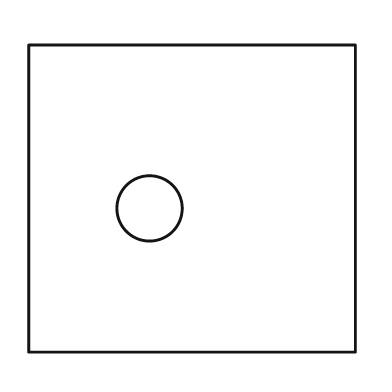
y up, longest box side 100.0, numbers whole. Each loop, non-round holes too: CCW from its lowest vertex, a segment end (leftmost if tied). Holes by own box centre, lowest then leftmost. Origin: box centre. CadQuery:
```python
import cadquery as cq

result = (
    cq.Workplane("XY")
    .moveTo(-50.0, -47.0)
    .lineTo(50.0, -47.0)
    .lineTo(50.0, 47.0)
    .lineTo(-50.0, 47.0)
    .close()
    .moveTo(-13.0, -3.0)
    .circle(10.0)
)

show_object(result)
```